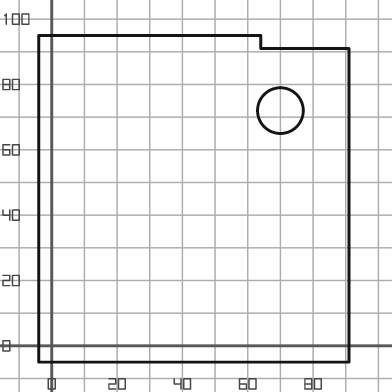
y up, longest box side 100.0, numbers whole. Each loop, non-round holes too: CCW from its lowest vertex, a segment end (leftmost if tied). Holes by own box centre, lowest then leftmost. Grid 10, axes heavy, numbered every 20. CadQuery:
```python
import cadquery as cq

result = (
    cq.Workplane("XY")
    .moveTo(-4.0, -5.0)
    .lineTo(91.0, -5.0)
    .lineTo(91.0, 91.0)
    .lineTo(64.0, 91.0)
    .lineTo(64.0, 95.0)
    .lineTo(-4.0, 95.0)
    .close()
    .moveTo(70.0, 72.0)
    .circle(7.0)
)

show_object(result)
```